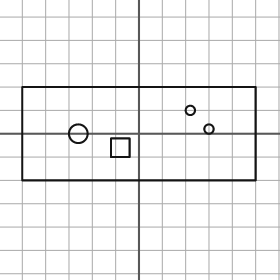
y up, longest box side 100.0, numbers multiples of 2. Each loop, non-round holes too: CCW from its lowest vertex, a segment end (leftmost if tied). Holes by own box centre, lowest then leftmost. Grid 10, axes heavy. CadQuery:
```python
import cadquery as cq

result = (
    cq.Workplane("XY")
    .moveTo(-50.0, -20.0)
    .lineTo(50.0, -20.0)
    .lineTo(50.0, 20.0)
    .lineTo(-50.0, 20.0)
    .close()
    .moveTo(-12.0, -10.0)
    .lineTo(-4.0, -10.0)
    .lineTo(-4.0, -2.0)
    .lineTo(-12.0, -2.0)
    .close()
    .moveTo(-26.0, 0.0)
    .circle(4.0)
    .moveTo(30.0, 2.0)
    .circle(2.0)
    .moveTo(22.0, 10.0)
    .circle(2.0)
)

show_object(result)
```